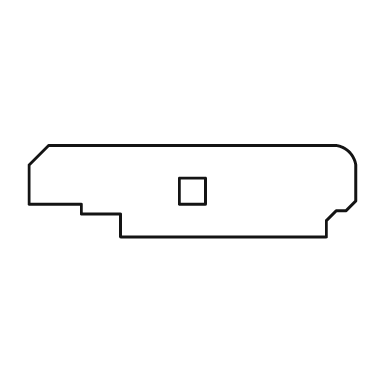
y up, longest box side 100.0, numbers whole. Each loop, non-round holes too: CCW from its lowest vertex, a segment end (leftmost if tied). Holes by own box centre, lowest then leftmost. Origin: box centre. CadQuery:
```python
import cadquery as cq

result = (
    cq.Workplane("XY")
    .moveTo(-22.0, -14.0)
    .lineTo(41.0, -14.0)
    .lineTo(41.0, -9.0)
    .lineTo(44.0, -6.0)
    .lineTo(47.0, -6.0)
    .lineTo(50.0, -3.0)
    .lineTo(50.0, 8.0)
    .threePointArc((48.0, 12.0), (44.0, 14.0))
    .lineTo(-44.0, 14.0)
    .lineTo(-50.0, 8.0)
    .lineTo(-50.0, -4.0)
    .lineTo(-34.0, -4.0)
    .lineTo(-34.0, -7.0)
    .lineTo(-22.0, -7.0)
    .close()
    .moveTo(-4.0, -4.0)
    .lineTo(4.0, -4.0)
    .lineTo(4.0, 4.0)
    .lineTo(-4.0, 4.0)
    .close()
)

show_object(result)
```